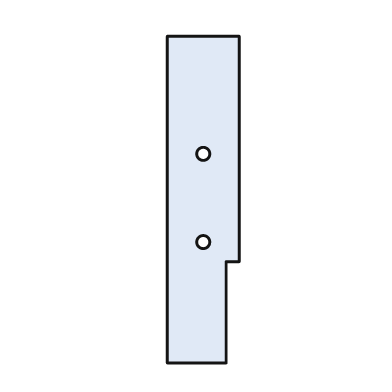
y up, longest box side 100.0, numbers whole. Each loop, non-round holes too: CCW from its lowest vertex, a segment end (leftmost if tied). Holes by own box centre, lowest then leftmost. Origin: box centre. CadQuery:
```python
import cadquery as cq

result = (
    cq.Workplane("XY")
    .moveTo(-11.0, -50.0)
    .lineTo(7.0, -50.0)
    .lineTo(7.0, -19.0)
    .lineTo(11.0, -19.0)
    .lineTo(11.0, 50.0)
    .lineTo(-11.0, 50.0)
    .close()
    .moveTo(0.0, -13.0)
    .circle(2.0)
    .moveTo(0.0, 14.0)
    .circle(2.0)
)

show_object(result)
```